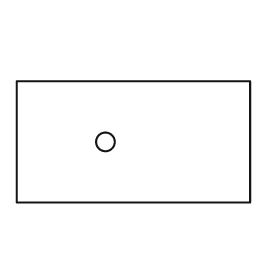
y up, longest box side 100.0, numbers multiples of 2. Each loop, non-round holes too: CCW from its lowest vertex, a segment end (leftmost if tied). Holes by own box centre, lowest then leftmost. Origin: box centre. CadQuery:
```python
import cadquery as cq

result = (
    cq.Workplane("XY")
    .moveTo(-50.0, -26.0)
    .lineTo(50.0, -26.0)
    .lineTo(50.0, 26.0)
    .lineTo(-50.0, 26.0)
    .close()
    .moveTo(-12.0, 0.0)
    .circle(4.0)
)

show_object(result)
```